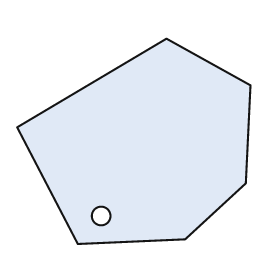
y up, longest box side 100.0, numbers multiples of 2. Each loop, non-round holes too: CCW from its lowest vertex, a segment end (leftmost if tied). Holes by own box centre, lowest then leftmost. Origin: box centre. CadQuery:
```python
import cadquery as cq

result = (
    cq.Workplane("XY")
    .moveTo(-24.0, -44.0)
    .lineTo(22.0, -42.0)
    .lineTo(48.0, -18.0)
    .lineTo(50.0, 24.0)
    .lineTo(14.0, 44.0)
    .lineTo(-50.0, 6.0)
    .close()
    .moveTo(-14.0, -32.0)
    .circle(4.0)
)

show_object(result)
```